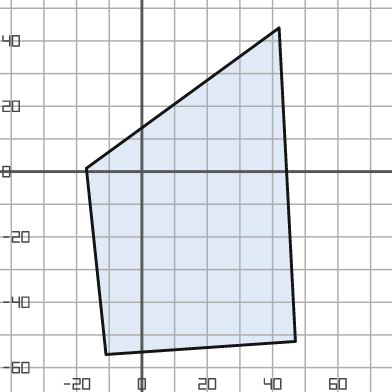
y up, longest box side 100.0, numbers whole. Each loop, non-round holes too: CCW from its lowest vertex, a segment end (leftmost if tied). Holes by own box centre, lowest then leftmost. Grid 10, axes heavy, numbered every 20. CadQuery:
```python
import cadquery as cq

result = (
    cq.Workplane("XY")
    .moveTo(-11.0, -56.0)
    .lineTo(47.0, -52.0)
    .lineTo(42.0, 44.0)
    .lineTo(-17.0, 1.0)
    .close()
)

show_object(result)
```